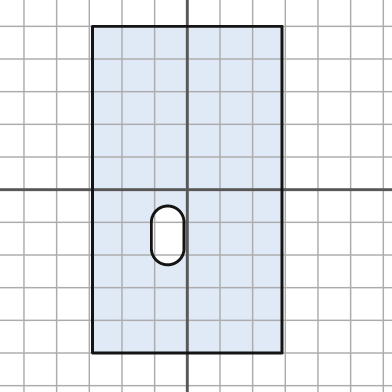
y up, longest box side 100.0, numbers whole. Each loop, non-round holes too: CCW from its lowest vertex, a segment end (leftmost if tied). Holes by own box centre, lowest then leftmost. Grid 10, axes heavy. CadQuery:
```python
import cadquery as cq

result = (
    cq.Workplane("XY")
    .moveTo(-29.0, -50.0)
    .lineTo(29.0, -50.0)
    .lineTo(29.0, 50.0)
    .lineTo(-29.0, 50.0)
    .close()
    .moveTo(-11.0, -18.0)
    .threePointArc((-6.0, -23.0), (-1.0, -18.0))
    .lineTo(-1.0, -10.0)
    .threePointArc((-6.0, -5.0), (-11.0, -10.0))
    .close()
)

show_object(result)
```